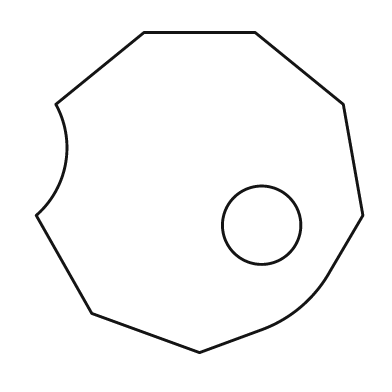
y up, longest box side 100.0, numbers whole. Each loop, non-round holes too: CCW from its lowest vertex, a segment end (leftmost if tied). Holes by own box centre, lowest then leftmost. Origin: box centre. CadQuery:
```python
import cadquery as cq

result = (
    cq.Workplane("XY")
    .moveTo(0.0, -49.0)
    .lineTo(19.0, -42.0)
    .threePointArc((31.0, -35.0), (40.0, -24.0))
    .lineTo(50.0, -7.0)
    .lineTo(44.0, 27.0)
    .lineTo(17.0, 49.0)
    .lineTo(-17.0, 49.0)
    .lineTo(-44.0, 27.0)
    .threePointArc((-41.0, 9.0), (-50.0, -7.0))
    .lineTo(-33.0, -37.0)
    .close()
    .moveTo(19.0, -10.0)
    .circle(12.0)
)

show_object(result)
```